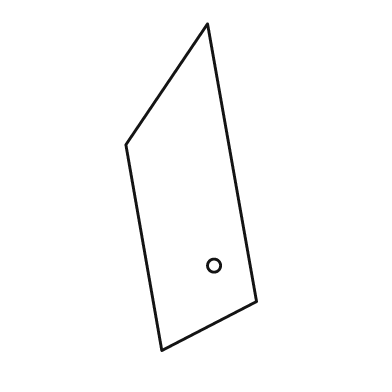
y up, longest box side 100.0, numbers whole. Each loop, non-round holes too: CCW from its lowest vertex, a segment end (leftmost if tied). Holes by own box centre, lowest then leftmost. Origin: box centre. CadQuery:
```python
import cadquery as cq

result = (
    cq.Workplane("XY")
    .moveTo(-9.0, -50.0)
    .lineTo(20.0, -35.0)
    .lineTo(5.0, 50.0)
    .lineTo(-20.0, 13.0)
    .close()
    .moveTo(7.0, -24.0)
    .circle(2.0)
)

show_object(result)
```